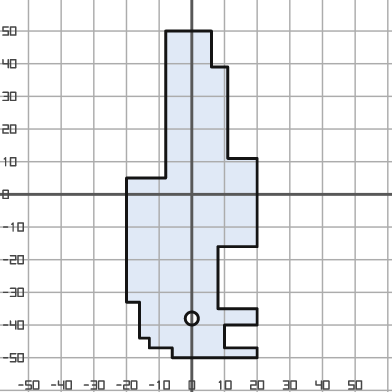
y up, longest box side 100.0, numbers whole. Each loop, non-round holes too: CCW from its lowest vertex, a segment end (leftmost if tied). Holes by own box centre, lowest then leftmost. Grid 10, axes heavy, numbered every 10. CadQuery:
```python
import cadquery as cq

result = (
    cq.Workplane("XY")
    .moveTo(-6.0, -50.0)
    .lineTo(20.0, -50.0)
    .lineTo(20.0, -47.0)
    .lineTo(10.0, -47.0)
    .lineTo(10.0, -40.0)
    .lineTo(20.0, -40.0)
    .lineTo(20.0, -35.0)
    .lineTo(8.0, -35.0)
    .lineTo(8.0, -16.0)
    .lineTo(20.0, -16.0)
    .lineTo(20.0, 11.0)
    .lineTo(11.0, 11.0)
    .lineTo(11.0, 39.0)
    .lineTo(6.0, 39.0)
    .lineTo(6.0, 50.0)
    .lineTo(-8.0, 50.0)
    .lineTo(-8.0, 5.0)
    .lineTo(-20.0, 5.0)
    .lineTo(-20.0, -33.0)
    .lineTo(-16.0, -33.0)
    .lineTo(-16.0, -44.0)
    .lineTo(-13.0, -44.0)
    .lineTo(-13.0, -47.0)
    .lineTo(-6.0, -47.0)
    .close()
    .moveTo(0.0, -38.0)
    .circle(2.0)
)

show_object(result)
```